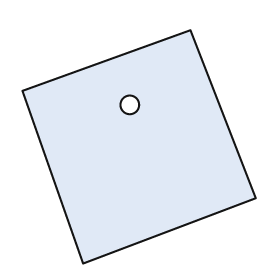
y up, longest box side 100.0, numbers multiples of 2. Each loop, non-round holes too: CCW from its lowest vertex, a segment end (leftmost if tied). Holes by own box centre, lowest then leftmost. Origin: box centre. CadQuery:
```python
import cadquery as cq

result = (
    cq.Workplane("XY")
    .moveTo(-24.0, -50.0)
    .lineTo(50.0, -22.0)
    .lineTo(22.0, 50.0)
    .lineTo(-50.0, 24.0)
    .close()
    .moveTo(-4.0, 18.0)
    .circle(4.0)
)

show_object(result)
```